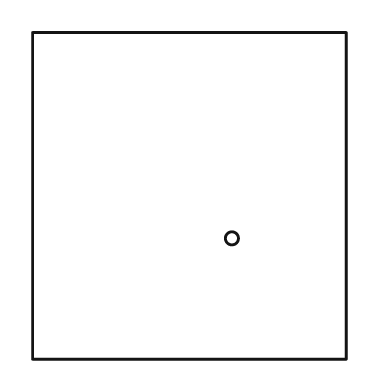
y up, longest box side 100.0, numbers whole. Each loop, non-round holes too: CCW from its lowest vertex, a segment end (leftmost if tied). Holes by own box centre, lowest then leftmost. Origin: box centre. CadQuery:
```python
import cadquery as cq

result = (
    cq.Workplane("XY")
    .moveTo(-48.0, -50.0)
    .lineTo(48.0, -50.0)
    .lineTo(48.0, 50.0)
    .lineTo(-48.0, 50.0)
    .close()
    .moveTo(13.0, -13.0)
    .circle(2.0)
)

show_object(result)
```